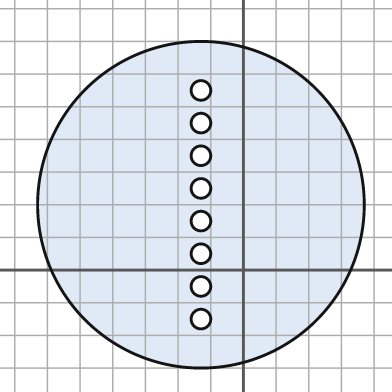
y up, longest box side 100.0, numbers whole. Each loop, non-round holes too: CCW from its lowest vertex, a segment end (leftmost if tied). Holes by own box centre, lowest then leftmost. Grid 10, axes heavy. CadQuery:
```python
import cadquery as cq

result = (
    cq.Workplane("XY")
    .moveTo(-13.0, 20.0)
    .circle(50.0)
    .moveTo(-13.0, -15.0)
    .circle(3.0)
    .moveTo(-13.0, -5.0)
    .circle(3.0)
    .moveTo(-13.0, 5.0)
    .circle(3.0)
    .moveTo(-13.0, 15.0)
    .circle(3.0)
    .moveTo(-13.0, 25.0)
    .circle(3.0)
    .moveTo(-13.0, 35.0)
    .circle(3.0)
    .moveTo(-13.0, 45.0)
    .circle(3.0)
    .moveTo(-13.0, 55.0)
    .circle(3.0)
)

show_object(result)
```